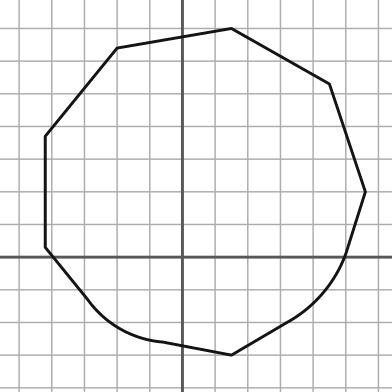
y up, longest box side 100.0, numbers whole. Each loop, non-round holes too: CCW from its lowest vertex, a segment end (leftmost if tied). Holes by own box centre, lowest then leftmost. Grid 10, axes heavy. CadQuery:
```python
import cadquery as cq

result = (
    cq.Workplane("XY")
    .moveTo(15.0, -30.0)
    .lineTo(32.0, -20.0)
    .threePointArc((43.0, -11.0), (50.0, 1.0))
    .lineTo(56.0, 20.0)
    .lineTo(45.0, 53.0)
    .lineTo(15.0, 70.0)
    .lineTo(-20.0, 64.0)
    .lineTo(-42.0, 37.0)
    .lineTo(-42.0, 3.0)
    .lineTo(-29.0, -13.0)
    .threePointArc((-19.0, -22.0), (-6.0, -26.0))
    .close()
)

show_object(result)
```